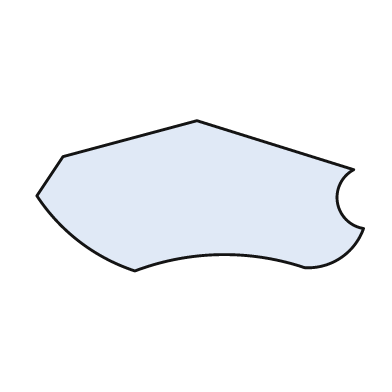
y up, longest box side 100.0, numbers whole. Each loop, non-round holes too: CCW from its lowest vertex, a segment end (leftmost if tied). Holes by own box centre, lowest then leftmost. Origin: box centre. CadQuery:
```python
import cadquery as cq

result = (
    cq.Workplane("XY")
    .moveTo(-20.0, -23.0)
    .threePointArc((6.0, -18.0), (32.0, -22.0))
    .threePointArc((43.0, -19.0), (50.0, -10.0))
    .threePointArc((42.0, -2.0), (47.0, 8.0))
    .lineTo(-1.0, 23.0)
    .lineTo(-42.0, 12.0)
    .lineTo(-50.0, 0.0)
    .threePointArc((-37.0, -14.0), (-20.0, -23.0))
    .close()
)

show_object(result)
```